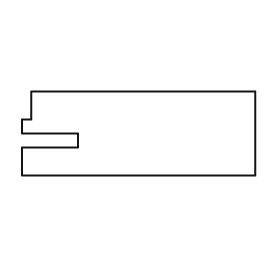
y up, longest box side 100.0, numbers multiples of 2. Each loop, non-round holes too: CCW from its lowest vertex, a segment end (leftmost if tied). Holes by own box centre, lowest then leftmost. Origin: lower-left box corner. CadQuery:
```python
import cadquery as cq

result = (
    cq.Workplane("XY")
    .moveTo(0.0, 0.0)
    .lineTo(100.0, 0.0)
    .lineTo(100.0, 36.0)
    .lineTo(4.0, 36.0)
    .lineTo(4.0, 24.0)
    .lineTo(0.0, 24.0)
    .lineTo(0.0, 18.0)
    .lineTo(24.0, 18.0)
    .lineTo(24.0, 12.0)
    .lineTo(0.0, 12.0)
    .close()
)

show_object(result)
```